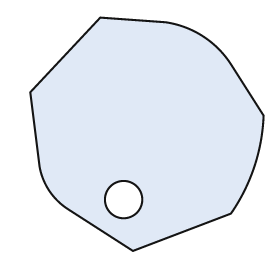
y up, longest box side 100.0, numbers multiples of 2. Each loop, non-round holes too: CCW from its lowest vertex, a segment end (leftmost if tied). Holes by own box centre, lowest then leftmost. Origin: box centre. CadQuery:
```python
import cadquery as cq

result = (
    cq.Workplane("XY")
    .moveTo(-6.0, -50.0)
    .lineTo(36.0, -34.0)
    .threePointArc((46.0, -14.0), (50.0, 8.0))
    .lineTo(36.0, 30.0)
    .threePointArc((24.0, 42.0), (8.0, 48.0))
    .lineTo(-20.0, 50.0)
    .lineTo(-50.0, 18.0)
    .lineTo(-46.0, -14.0)
    .threePointArc((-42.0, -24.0), (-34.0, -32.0))
    .close()
    .moveTo(-10.0, -28.0)
    .circle(8.0)
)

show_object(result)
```